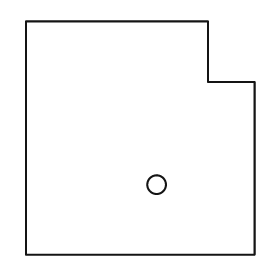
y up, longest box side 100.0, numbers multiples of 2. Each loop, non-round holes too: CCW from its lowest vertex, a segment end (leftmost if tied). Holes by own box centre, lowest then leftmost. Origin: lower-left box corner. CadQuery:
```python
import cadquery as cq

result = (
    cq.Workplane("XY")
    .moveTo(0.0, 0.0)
    .lineTo(98.0, 0.0)
    .lineTo(98.0, 74.0)
    .lineTo(78.0, 74.0)
    .lineTo(78.0, 100.0)
    .lineTo(0.0, 100.0)
    .close()
    .moveTo(56.0, 30.0)
    .circle(4.0)
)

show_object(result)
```